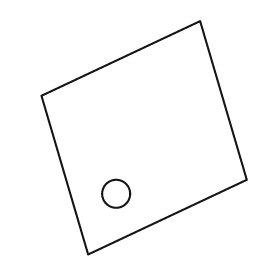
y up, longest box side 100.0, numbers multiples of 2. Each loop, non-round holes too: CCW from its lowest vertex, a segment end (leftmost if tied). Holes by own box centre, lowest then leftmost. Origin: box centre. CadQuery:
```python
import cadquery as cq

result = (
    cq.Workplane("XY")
    .moveTo(-24.0, -50.0)
    .lineTo(44.0, -18.0)
    .lineTo(24.0, 50.0)
    .lineTo(-44.0, 18.0)
    .close()
    .moveTo(-12.0, -24.0)
    .circle(6.0)
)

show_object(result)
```